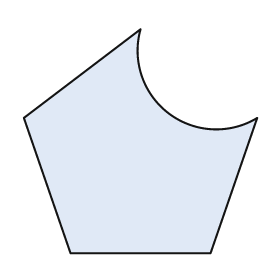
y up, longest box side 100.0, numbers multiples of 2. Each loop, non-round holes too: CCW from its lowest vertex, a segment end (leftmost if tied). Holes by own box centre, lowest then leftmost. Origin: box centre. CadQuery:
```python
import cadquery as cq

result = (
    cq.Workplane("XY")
    .moveTo(-30.0, -48.0)
    .lineTo(30.0, -48.0)
    .lineTo(50.0, 10.0)
    .threePointArc((12.0, 12.0), (0.0, 48.0))
    .lineTo(-50.0, 10.0)
    .close()
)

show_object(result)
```